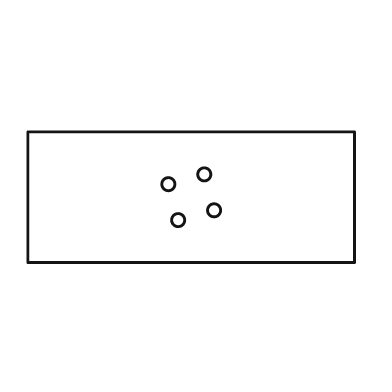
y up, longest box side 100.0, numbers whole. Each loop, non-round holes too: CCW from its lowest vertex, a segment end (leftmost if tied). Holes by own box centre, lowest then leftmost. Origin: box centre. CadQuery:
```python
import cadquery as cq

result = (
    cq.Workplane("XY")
    .moveTo(-50.0, -20.0)
    .lineTo(50.0, -20.0)
    .lineTo(50.0, 20.0)
    .lineTo(-50.0, 20.0)
    .close()
    .moveTo(-4.0, -7.0)
    .circle(2.0)
    .moveTo(7.0, -4.0)
    .circle(2.0)
    .moveTo(-7.0, 4.0)
    .circle(2.0)
    .moveTo(4.0, 7.0)
    .circle(2.0)
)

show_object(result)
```